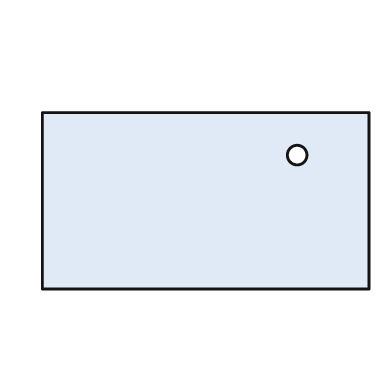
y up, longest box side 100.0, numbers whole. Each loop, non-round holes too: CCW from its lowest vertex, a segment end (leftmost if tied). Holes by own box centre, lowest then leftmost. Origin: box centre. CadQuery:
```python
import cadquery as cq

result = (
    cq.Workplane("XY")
    .moveTo(-50.0, -27.0)
    .lineTo(50.0, -27.0)
    .lineTo(50.0, 27.0)
    .lineTo(-50.0, 27.0)
    .close()
    .moveTo(28.0, 14.0)
    .circle(3.0)
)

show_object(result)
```